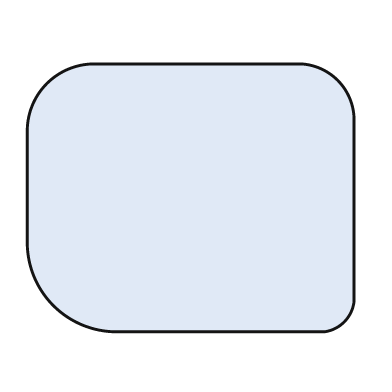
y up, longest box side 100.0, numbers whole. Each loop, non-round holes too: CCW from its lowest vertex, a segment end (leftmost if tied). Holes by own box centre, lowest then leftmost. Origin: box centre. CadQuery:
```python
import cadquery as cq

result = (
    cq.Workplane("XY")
    .moveTo(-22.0, -41.0)
    .lineTo(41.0, -41.0)
    .threePointArc((47.0, -38.0), (50.0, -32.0))
    .lineTo(50.0, 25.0)
    .threePointArc((45.0, 36.0), (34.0, 41.0))
    .lineTo(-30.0, 41.0)
    .threePointArc((-44.0, 35.0), (-50.0, 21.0))
    .lineTo(-50.0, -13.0)
    .threePointArc((-42.0, -33.0), (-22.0, -41.0))
    .close()
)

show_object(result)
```